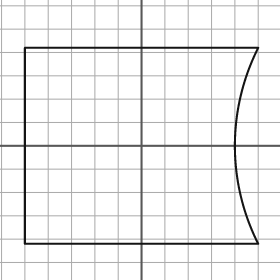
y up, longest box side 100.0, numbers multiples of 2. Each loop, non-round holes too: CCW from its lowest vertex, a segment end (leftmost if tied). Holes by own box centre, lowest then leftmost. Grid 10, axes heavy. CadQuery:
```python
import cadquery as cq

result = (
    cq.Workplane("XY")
    .moveTo(-50.0, -42.0)
    .lineTo(50.0, -42.0)
    .threePointArc((40.0, 0.0), (50.0, 42.0))
    .lineTo(-50.0, 42.0)
    .close()
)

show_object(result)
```